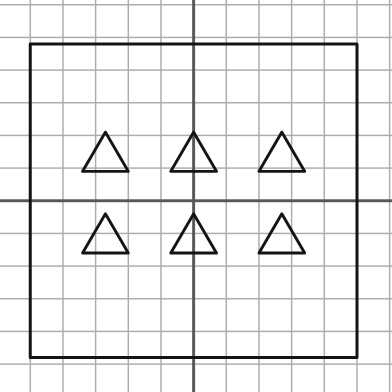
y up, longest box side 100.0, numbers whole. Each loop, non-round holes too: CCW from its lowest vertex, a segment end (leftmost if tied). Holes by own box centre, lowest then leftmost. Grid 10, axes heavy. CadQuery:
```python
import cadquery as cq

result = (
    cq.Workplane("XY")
    .moveTo(-50.0, -48.0)
    .lineTo(50.0, -48.0)
    .lineTo(50.0, 48.0)
    .lineTo(-50.0, 48.0)
    .close()
    .moveTo(-34.0, -16.0)
    .lineTo(-20.0, -16.0)
    .lineTo(-27.0, -4.0)
    .close()
    .moveTo(-7.0, -16.0)
    .lineTo(7.0, -16.0)
    .lineTo(0.0, -4.0)
    .close()
    .moveTo(20.0, -16.0)
    .lineTo(34.0, -16.0)
    .lineTo(27.0, -4.0)
    .close()
    .moveTo(-34.0, 9.0)
    .lineTo(-20.0, 9.0)
    .lineTo(-27.0, 21.0)
    .close()
    .moveTo(-7.0, 9.0)
    .lineTo(7.0, 9.0)
    .lineTo(0.0, 21.0)
    .close()
    .moveTo(20.0, 9.0)
    .lineTo(34.0, 9.0)
    .lineTo(27.0, 21.0)
    .close()
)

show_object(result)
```